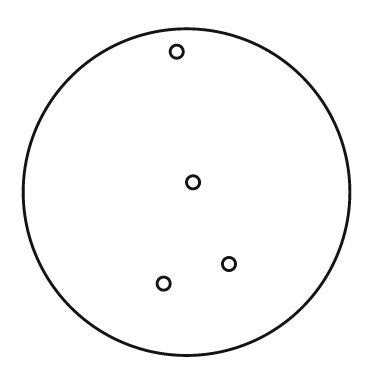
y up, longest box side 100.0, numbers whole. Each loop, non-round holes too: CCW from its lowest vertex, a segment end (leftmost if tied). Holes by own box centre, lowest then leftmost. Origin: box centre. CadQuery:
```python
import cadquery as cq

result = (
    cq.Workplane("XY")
    .moveTo(0.0, 0.0)
    .circle(50.0)
    .moveTo(-7.0, -28.0)
    .circle(2.0)
    .moveTo(13.0, -22.0)
    .circle(2.0)
    .moveTo(2.0, 3.0)
    .circle(2.0)
    .moveTo(-3.0, 43.0)
    .circle(2.0)
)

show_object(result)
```